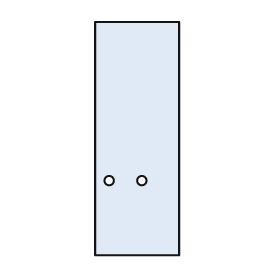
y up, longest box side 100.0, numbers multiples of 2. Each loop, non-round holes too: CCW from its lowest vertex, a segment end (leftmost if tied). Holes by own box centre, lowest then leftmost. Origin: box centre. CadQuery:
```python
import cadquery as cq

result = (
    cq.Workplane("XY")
    .moveTo(-18.0, -50.0)
    .lineTo(18.0, -50.0)
    .lineTo(18.0, 50.0)
    .lineTo(-18.0, 50.0)
    .close()
    .moveTo(-12.0, -18.0)
    .circle(2.0)
    .moveTo(2.0, -18.0)
    .circle(2.0)
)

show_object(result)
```